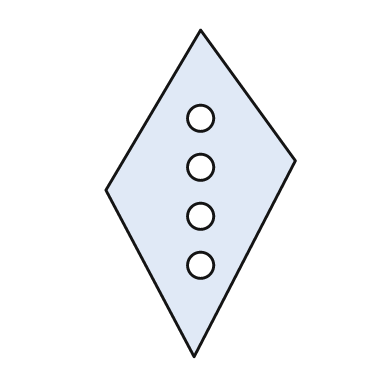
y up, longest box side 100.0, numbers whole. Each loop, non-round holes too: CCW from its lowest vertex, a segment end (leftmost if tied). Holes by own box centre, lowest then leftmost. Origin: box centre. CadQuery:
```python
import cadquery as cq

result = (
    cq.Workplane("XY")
    .moveTo(-2.0, -50.0)
    .lineTo(29.0, 10.0)
    .lineTo(0.0, 50.0)
    .lineTo(-29.0, 1.0)
    .close()
    .moveTo(0.0, -22.0)
    .circle(4.0)
    .moveTo(0.0, -7.0)
    .circle(4.0)
    .moveTo(0.0, 8.0)
    .circle(4.0)
    .moveTo(0.0, 23.0)
    .circle(4.0)
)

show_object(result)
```